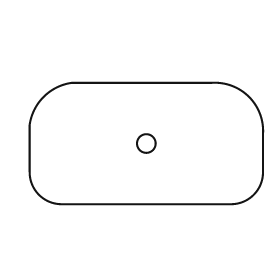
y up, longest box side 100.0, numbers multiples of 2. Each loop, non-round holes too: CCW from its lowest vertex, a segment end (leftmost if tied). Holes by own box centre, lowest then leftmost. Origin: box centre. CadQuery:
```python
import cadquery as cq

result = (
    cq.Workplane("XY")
    .moveTo(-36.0, -26.0)
    .lineTo(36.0, -26.0)
    .threePointArc((46.0, -22.0), (50.0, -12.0))
    .lineTo(50.0, 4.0)
    .threePointArc((44.0, 20.0), (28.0, 26.0))
    .lineTo(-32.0, 26.0)
    .threePointArc((-44.0, 20.0), (-50.0, 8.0))
    .lineTo(-50.0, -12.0)
    .threePointArc((-46.0, -22.0), (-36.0, -26.0))
    .close()
    .moveTo(0.0, 0.0)
    .circle(4.0)
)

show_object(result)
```